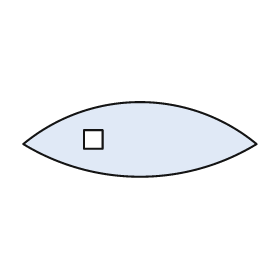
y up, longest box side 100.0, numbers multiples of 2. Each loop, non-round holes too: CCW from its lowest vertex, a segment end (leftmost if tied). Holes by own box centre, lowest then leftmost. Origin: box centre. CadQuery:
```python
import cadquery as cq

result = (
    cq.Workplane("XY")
    .moveTo(-50.0, -2.0)
    .threePointArc((0.0, -16.0), (50.0, -2.0))
    .threePointArc((0.0, 16.0), (-50.0, -2.0))
    .close()
    .moveTo(-24.0, -4.0)
    .lineTo(-16.0, -4.0)
    .lineTo(-16.0, 4.0)
    .lineTo(-24.0, 4.0)
    .close()
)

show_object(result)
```